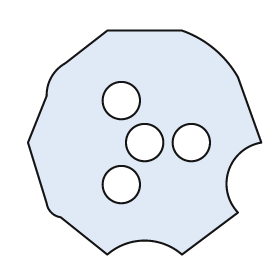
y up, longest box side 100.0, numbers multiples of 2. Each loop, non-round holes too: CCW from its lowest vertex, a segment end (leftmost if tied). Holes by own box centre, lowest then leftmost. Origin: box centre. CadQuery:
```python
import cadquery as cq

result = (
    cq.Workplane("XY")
    .moveTo(-16.0, -48.0)
    .threePointArc((0.0, -42.0), (16.0, -48.0))
    .lineTo(40.0, -30.0)
    .threePointArc((36.0, -12.0), (50.0, 0.0))
    .lineTo(40.0, 28.0)
    .threePointArc((30.0, 40.0), (16.0, 48.0))
    .lineTo(-16.0, 48.0)
    .lineTo(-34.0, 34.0)
    .threePointArc((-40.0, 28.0), (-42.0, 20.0))
    .lineTo(-50.0, 0.0)
    .lineTo(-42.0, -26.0)
    .threePointArc((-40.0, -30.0), (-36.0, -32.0))
    .close()
    .moveTo(-10.0, -18.0)
    .circle(8.0)
    .moveTo(0.0, 0.0)
    .circle(8.0)
    .moveTo(20.0, 0.0)
    .circle(8.0)
    .moveTo(-10.0, 18.0)
    .circle(8.0)
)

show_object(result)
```